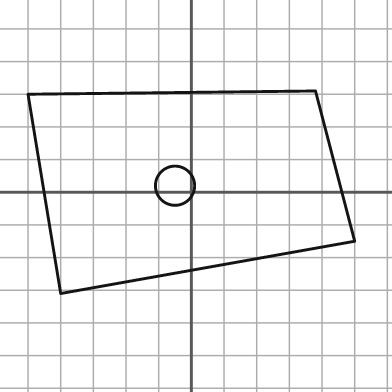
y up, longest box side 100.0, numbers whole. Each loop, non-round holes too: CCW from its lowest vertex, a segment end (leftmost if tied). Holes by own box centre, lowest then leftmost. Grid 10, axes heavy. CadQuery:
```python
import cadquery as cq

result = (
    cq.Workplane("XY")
    .moveTo(-40.0, -31.0)
    .lineTo(50.0, -15.0)
    .lineTo(38.0, 31.0)
    .lineTo(-50.0, 30.0)
    .close()
    .moveTo(-5.0, 2.0)
    .circle(6.0)
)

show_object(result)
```